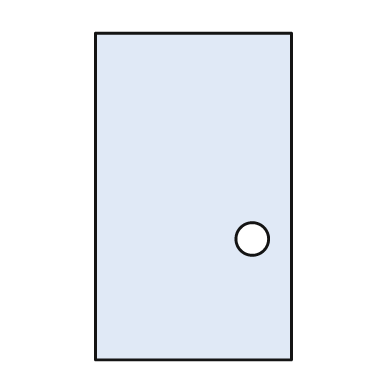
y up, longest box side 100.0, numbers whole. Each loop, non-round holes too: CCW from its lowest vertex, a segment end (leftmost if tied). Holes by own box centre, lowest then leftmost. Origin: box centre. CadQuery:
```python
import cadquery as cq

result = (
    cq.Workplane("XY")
    .moveTo(-30.0, -50.0)
    .lineTo(30.0, -50.0)
    .lineTo(30.0, 50.0)
    .lineTo(-30.0, 50.0)
    .close()
    .moveTo(18.0, -13.0)
    .circle(5.0)
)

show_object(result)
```